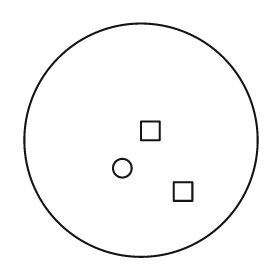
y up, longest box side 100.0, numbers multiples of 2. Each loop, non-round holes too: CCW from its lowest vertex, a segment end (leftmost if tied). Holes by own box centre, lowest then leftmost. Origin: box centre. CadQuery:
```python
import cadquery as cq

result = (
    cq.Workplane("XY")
    .moveTo(0.0, 0.0)
    .circle(50.0)
    .moveTo(14.0, -26.0)
    .lineTo(22.0, -26.0)
    .lineTo(22.0, -18.0)
    .lineTo(14.0, -18.0)
    .close()
    .moveTo(-8.0, -12.0)
    .circle(4.0)
    .moveTo(0.0, 0.0)
    .lineTo(8.0, 0.0)
    .lineTo(8.0, 8.0)
    .lineTo(0.0, 8.0)
    .close()
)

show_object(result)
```